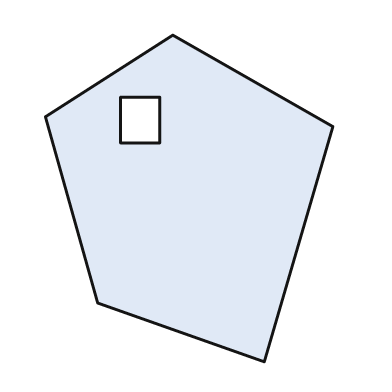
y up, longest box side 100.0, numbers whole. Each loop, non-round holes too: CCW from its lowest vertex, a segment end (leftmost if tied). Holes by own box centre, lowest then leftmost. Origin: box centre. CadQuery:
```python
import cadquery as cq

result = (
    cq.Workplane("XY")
    .moveTo(23.0, -50.0)
    .lineTo(44.0, 22.0)
    .lineTo(-5.0, 50.0)
    .lineTo(-44.0, 25.0)
    .lineTo(-28.0, -32.0)
    .close()
    .moveTo(-21.0, 17.0)
    .lineTo(-9.0, 17.0)
    .lineTo(-9.0, 31.0)
    .lineTo(-21.0, 31.0)
    .close()
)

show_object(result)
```